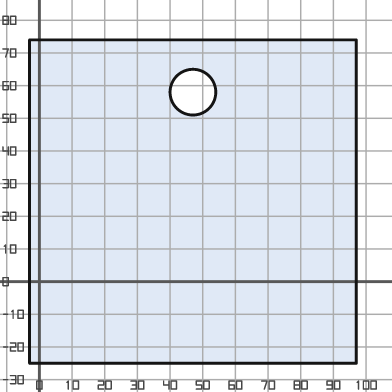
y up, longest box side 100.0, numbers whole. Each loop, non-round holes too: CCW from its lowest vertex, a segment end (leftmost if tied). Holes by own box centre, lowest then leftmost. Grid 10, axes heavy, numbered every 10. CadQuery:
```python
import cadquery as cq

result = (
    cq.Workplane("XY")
    .moveTo(-3.0, -25.0)
    .lineTo(97.0, -25.0)
    .lineTo(97.0, 74.0)
    .lineTo(-3.0, 74.0)
    .close()
    .moveTo(47.0, 58.0)
    .circle(7.0)
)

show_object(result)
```